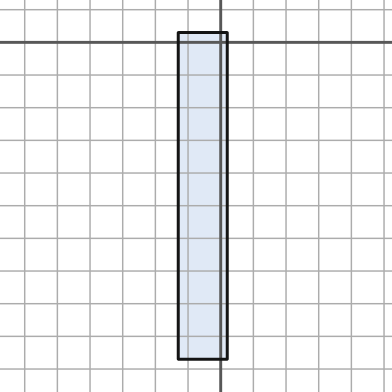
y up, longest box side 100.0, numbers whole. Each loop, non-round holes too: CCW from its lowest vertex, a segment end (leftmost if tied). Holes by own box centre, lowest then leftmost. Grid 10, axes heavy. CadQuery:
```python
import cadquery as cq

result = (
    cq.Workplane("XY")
    .moveTo(-13.0, -97.0)
    .lineTo(2.0, -97.0)
    .lineTo(2.0, 3.0)
    .lineTo(-13.0, 3.0)
    .close()
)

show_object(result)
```